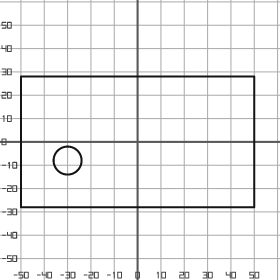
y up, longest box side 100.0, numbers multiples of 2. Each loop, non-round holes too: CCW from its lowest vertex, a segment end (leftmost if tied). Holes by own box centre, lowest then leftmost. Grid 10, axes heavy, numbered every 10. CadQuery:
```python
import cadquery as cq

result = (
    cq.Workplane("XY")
    .moveTo(-50.0, -28.0)
    .lineTo(50.0, -28.0)
    .lineTo(50.0, 28.0)
    .lineTo(-50.0, 28.0)
    .close()
    .moveTo(-30.0, -8.0)
    .circle(6.0)
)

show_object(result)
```